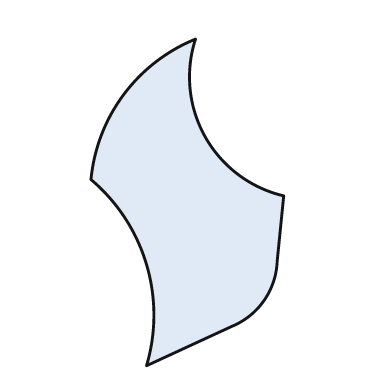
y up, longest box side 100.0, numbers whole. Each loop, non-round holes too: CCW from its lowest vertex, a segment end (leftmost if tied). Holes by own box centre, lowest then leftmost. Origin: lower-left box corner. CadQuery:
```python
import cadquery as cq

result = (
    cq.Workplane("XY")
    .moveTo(17.0, 0.0)
    .lineTo(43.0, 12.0)
    .threePointArc((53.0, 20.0), (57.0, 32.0))
    .lineTo(59.0, 52.0)
    .threePointArc((35.0, 70.0), (32.0, 100.0))
    .threePointArc((10.0, 83.0), (0.0, 57.0))
    .threePointArc((17.0, 31.0), (17.0, 0.0))
    .close()
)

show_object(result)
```